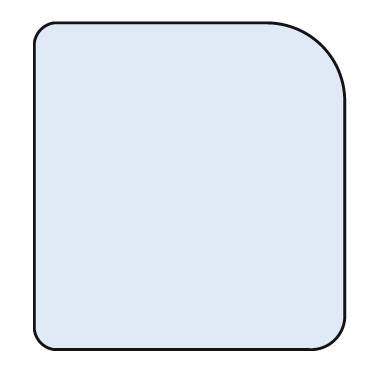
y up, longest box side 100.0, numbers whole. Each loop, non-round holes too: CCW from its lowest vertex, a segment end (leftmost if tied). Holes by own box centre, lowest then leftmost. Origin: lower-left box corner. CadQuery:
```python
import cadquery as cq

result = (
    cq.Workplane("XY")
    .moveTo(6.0, 0.0)
    .lineTo(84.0, 0.0)
    .threePointArc((92.0, 3.0), (95.0, 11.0))
    .lineTo(95.0, 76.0)
    .threePointArc((88.0, 93.0), (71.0, 100.0))
    .lineTo(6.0, 100.0)
    .threePointArc((2.0, 98.0), (0.0, 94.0))
    .lineTo(0.0, 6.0)
    .threePointArc((2.0, 2.0), (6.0, 0.0))
    .close()
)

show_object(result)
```